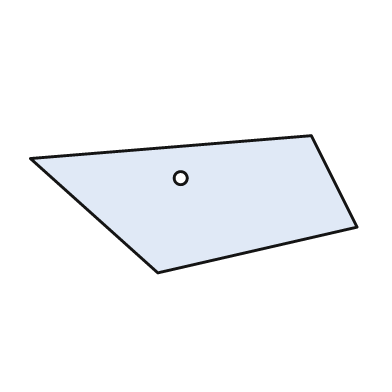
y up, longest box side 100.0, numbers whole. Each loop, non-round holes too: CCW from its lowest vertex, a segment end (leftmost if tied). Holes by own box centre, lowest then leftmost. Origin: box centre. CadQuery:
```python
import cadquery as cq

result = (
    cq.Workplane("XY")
    .moveTo(-11.0, -21.0)
    .lineTo(50.0, -7.0)
    .lineTo(36.0, 21.0)
    .lineTo(-50.0, 14.0)
    .close()
    .moveTo(-4.0, 8.0)
    .circle(2.0)
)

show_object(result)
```